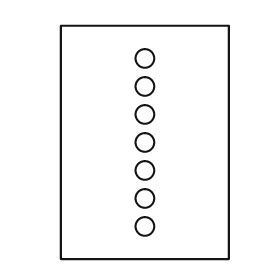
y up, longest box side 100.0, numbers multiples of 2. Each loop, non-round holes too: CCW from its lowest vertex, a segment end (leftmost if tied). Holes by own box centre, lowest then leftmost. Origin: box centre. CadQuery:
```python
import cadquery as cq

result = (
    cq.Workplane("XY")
    .moveTo(-36.0, -50.0)
    .lineTo(36.0, -50.0)
    .lineTo(36.0, 50.0)
    .lineTo(-36.0, 50.0)
    .close()
    .moveTo(0.0, -36.0)
    .circle(4.0)
    .moveTo(0.0, -24.0)
    .circle(4.0)
    .moveTo(0.0, -12.0)
    .circle(4.0)
    .moveTo(0.0, 0.0)
    .circle(4.0)
    .moveTo(0.0, 12.0)
    .circle(4.0)
    .moveTo(0.0, 24.0)
    .circle(4.0)
    .moveTo(0.0, 36.0)
    .circle(4.0)
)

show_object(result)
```